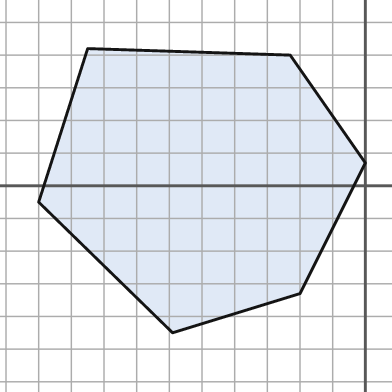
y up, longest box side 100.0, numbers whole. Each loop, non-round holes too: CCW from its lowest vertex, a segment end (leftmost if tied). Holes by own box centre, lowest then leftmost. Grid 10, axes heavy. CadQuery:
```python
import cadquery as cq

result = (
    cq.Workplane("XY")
    .moveTo(-59.0, -45.0)
    .lineTo(-20.0, -33.0)
    .lineTo(0.0, 7.0)
    .lineTo(-23.0, 40.0)
    .lineTo(-85.0, 42.0)
    .lineTo(-100.0, -5.0)
    .close()
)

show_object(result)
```